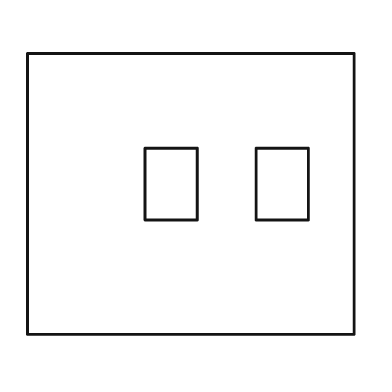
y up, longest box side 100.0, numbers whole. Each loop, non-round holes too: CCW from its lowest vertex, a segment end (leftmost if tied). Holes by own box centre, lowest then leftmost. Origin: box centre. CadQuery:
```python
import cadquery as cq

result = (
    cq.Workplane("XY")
    .moveTo(-50.0, -43.0)
    .lineTo(50.0, -43.0)
    .lineTo(50.0, 43.0)
    .lineTo(-50.0, 43.0)
    .close()
    .moveTo(-14.0, -8.0)
    .lineTo(2.0, -8.0)
    .lineTo(2.0, 14.0)
    .lineTo(-14.0, 14.0)
    .close()
    .moveTo(20.0, -8.0)
    .lineTo(36.0, -8.0)
    .lineTo(36.0, 14.0)
    .lineTo(20.0, 14.0)
    .close()
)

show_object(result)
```